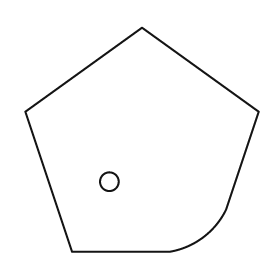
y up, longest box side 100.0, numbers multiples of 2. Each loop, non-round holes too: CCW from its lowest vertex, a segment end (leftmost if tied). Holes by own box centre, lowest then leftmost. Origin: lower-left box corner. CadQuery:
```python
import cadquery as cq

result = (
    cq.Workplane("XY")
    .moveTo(20.0, 0.0)
    .lineTo(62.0, 0.0)
    .threePointArc((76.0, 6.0), (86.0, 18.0))
    .lineTo(100.0, 60.0)
    .lineTo(50.0, 96.0)
    .lineTo(0.0, 60.0)
    .close()
    .moveTo(36.0, 30.0)
    .circle(4.0)
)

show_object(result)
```